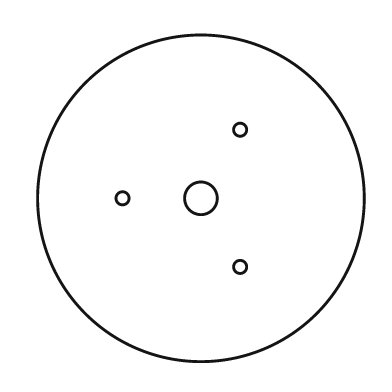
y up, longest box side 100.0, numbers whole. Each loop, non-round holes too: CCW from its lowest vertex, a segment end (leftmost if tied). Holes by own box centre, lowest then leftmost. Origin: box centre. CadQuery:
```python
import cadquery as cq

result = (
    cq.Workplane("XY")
    .moveTo(0.0, 0.0)
    .circle(50.0)
    .moveTo(12.0, -21.0)
    .circle(2.0)
    .moveTo(-24.0, 0.0)
    .circle(2.0)
    .moveTo(0.0, 0.0)
    .circle(5.0)
    .moveTo(12.0, 21.0)
    .circle(2.0)
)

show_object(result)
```